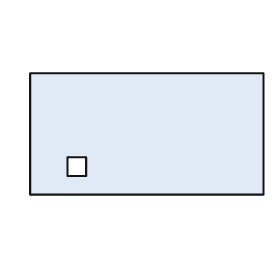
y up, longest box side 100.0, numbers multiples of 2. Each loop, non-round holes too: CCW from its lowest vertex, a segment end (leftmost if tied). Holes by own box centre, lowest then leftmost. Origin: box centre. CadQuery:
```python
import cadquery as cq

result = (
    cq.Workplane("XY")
    .moveTo(-50.0, -26.0)
    .lineTo(50.0, -26.0)
    .lineTo(50.0, 26.0)
    .lineTo(-50.0, 26.0)
    .close()
    .moveTo(-34.0, -18.0)
    .lineTo(-26.0, -18.0)
    .lineTo(-26.0, -10.0)
    .lineTo(-34.0, -10.0)
    .close()
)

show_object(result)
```